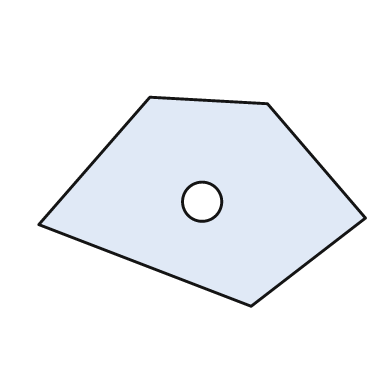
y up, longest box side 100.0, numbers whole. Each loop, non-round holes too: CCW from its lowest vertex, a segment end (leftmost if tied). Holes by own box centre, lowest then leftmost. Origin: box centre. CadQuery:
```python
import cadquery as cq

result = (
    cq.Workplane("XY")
    .moveTo(15.0, -32.0)
    .lineTo(50.0, -5.0)
    .lineTo(20.0, 30.0)
    .lineTo(-16.0, 32.0)
    .lineTo(-50.0, -7.0)
    .close()
    .moveTo(0.0, 0.0)
    .circle(6.0)
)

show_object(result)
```